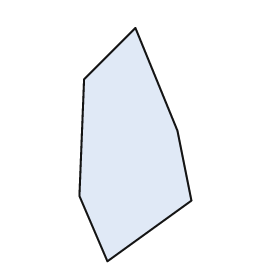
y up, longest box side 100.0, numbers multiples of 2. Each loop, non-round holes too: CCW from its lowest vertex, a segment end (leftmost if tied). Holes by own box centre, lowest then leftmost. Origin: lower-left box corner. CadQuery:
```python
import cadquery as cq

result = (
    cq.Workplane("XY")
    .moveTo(12.0, 0.0)
    .lineTo(48.0, 26.0)
    .lineTo(42.0, 56.0)
    .lineTo(24.0, 100.0)
    .lineTo(2.0, 78.0)
    .lineTo(0.0, 28.0)
    .close()
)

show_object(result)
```